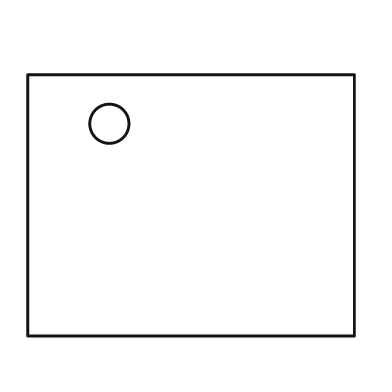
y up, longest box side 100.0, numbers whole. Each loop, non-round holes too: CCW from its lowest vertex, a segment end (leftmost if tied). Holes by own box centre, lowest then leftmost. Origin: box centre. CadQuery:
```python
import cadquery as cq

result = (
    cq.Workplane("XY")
    .moveTo(-50.0, -40.0)
    .lineTo(50.0, -40.0)
    .lineTo(50.0, 40.0)
    .lineTo(-50.0, 40.0)
    .close()
    .moveTo(-25.0, 25.0)
    .circle(6.0)
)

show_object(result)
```